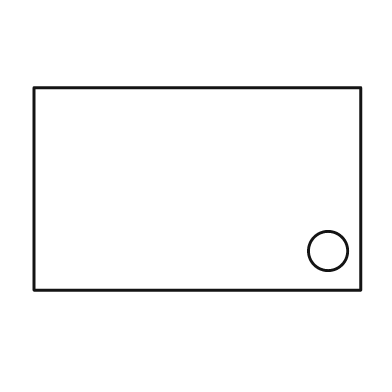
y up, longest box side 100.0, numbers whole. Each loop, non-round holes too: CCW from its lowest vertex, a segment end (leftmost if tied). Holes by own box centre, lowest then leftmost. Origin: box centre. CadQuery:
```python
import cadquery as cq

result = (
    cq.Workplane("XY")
    .moveTo(-50.0, -31.0)
    .lineTo(50.0, -31.0)
    .lineTo(50.0, 31.0)
    .lineTo(-50.0, 31.0)
    .close()
    .moveTo(40.0, -19.0)
    .circle(6.0)
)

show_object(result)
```